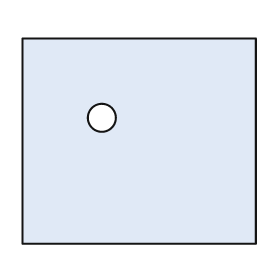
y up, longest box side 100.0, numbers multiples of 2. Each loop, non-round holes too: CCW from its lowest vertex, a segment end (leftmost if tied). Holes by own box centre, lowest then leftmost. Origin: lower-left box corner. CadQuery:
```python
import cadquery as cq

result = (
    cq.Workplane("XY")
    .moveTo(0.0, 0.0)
    .lineTo(100.0, 0.0)
    .lineTo(100.0, 88.0)
    .lineTo(0.0, 88.0)
    .close()
    .moveTo(34.0, 54.0)
    .circle(6.0)
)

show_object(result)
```